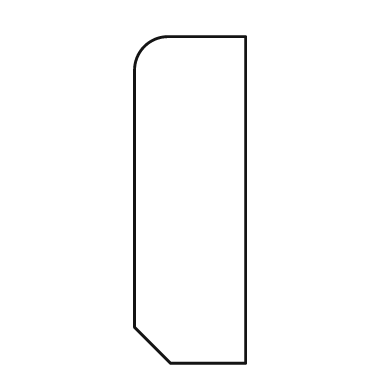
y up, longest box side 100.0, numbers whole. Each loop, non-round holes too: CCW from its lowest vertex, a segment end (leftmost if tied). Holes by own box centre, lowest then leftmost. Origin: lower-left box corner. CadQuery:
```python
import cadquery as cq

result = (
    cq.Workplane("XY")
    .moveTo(11.0, 0.0)
    .lineTo(34.0, 0.0)
    .lineTo(34.0, 100.0)
    .lineTo(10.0, 100.0)
    .threePointArc((3.0, 97.0), (0.0, 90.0))
    .lineTo(0.0, 11.0)
    .close()
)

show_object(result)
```